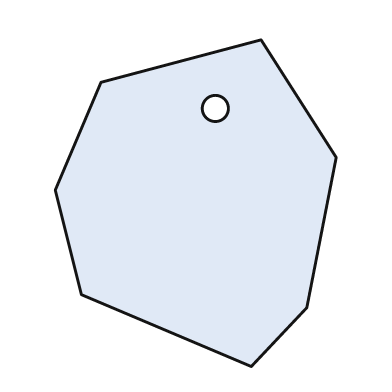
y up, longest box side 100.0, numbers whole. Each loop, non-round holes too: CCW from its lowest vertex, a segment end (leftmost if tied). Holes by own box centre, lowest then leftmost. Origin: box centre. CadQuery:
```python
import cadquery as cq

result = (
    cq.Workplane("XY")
    .moveTo(17.0, -50.0)
    .lineTo(34.0, -32.0)
    .lineTo(43.0, 14.0)
    .lineTo(20.0, 50.0)
    .lineTo(-29.0, 37.0)
    .lineTo(-43.0, 4.0)
    .lineTo(-35.0, -28.0)
    .close()
    .moveTo(6.0, 29.0)
    .circle(4.0)
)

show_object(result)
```